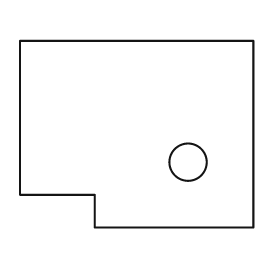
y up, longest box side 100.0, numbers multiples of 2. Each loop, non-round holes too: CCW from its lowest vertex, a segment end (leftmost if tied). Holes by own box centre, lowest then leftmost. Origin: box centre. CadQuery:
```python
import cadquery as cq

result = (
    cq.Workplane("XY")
    .moveTo(-18.0, -40.0)
    .lineTo(50.0, -40.0)
    .lineTo(50.0, 40.0)
    .lineTo(-50.0, 40.0)
    .lineTo(-50.0, -26.0)
    .lineTo(-18.0, -26.0)
    .close()
    .moveTo(22.0, -12.0)
    .circle(8.0)
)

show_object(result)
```